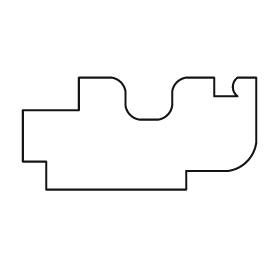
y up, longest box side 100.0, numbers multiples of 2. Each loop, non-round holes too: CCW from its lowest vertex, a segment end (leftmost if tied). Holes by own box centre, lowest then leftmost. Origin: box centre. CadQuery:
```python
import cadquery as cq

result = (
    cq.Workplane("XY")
    .moveTo(-40.0, -24.0)
    .lineTo(20.0, -24.0)
    .lineTo(20.0, -16.0)
    .lineTo(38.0, -16.0)
    .threePointArc((46.0, -12.0), (50.0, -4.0))
    .lineTo(50.0, 24.0)
    .lineTo(42.0, 24.0)
    .threePointArc((40.0, 20.0), (42.0, 16.0))
    .lineTo(32.0, 16.0)
    .lineTo(32.0, 24.0)
    .lineTo(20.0, 24.0)
    .threePointArc((16.0, 22.0), (14.0, 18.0))
    .lineTo(14.0, 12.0)
    .threePointArc((12.0, 8.0), (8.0, 6.0))
    .lineTo(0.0, 6.0)
    .threePointArc((-4.0, 8.0), (-6.0, 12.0))
    .lineTo(-6.0, 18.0)
    .threePointArc((-8.0, 22.0), (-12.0, 24.0))
    .lineTo(-26.0, 24.0)
    .lineTo(-26.0, 10.0)
    .lineTo(-50.0, 10.0)
    .lineTo(-50.0, -12.0)
    .lineTo(-40.0, -12.0)
    .close()
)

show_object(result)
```